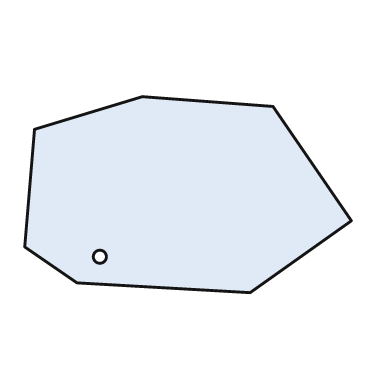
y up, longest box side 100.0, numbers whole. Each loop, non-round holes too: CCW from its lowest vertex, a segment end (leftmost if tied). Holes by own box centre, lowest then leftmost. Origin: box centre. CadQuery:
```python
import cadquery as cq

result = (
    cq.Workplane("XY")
    .moveTo(19.0, -30.0)
    .lineTo(50.0, -8.0)
    .lineTo(26.0, 27.0)
    .lineTo(-14.0, 30.0)
    .lineTo(-47.0, 20.0)
    .lineTo(-50.0, -16.0)
    .lineTo(-34.0, -27.0)
    .close()
    .moveTo(-27.0, -19.0)
    .circle(2.0)
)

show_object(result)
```